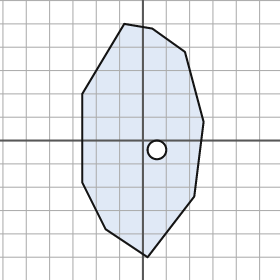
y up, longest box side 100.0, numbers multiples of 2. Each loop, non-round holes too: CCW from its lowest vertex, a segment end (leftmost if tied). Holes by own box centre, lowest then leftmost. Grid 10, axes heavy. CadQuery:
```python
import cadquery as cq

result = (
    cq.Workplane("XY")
    .moveTo(2.0, -50.0)
    .lineTo(22.0, -24.0)
    .lineTo(26.0, 8.0)
    .lineTo(18.0, 38.0)
    .lineTo(4.0, 48.0)
    .lineTo(-8.0, 50.0)
    .lineTo(-26.0, 20.0)
    .lineTo(-26.0, -18.0)
    .lineTo(-16.0, -38.0)
    .close()
    .moveTo(6.0, -4.0)
    .circle(4.0)
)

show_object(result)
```